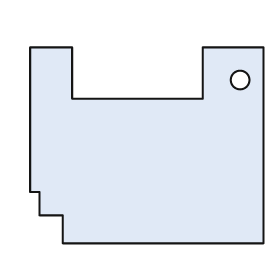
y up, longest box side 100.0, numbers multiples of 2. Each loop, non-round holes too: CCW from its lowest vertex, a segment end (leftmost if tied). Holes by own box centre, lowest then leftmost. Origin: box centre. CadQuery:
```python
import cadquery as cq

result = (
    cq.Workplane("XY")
    .moveTo(-36.0, -42.0)
    .lineTo(50.0, -42.0)
    .lineTo(50.0, 42.0)
    .lineTo(24.0, 42.0)
    .lineTo(24.0, 20.0)
    .lineTo(-32.0, 20.0)
    .lineTo(-32.0, 42.0)
    .lineTo(-50.0, 42.0)
    .lineTo(-50.0, -20.0)
    .lineTo(-46.0, -20.0)
    .lineTo(-46.0, -30.0)
    .lineTo(-36.0, -30.0)
    .close()
    .moveTo(40.0, 28.0)
    .circle(4.0)
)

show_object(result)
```